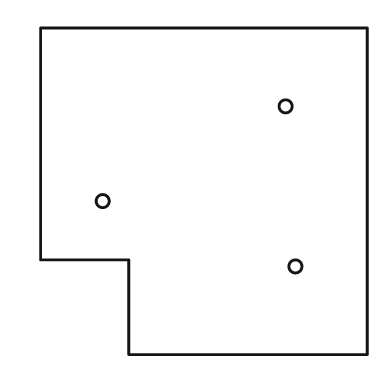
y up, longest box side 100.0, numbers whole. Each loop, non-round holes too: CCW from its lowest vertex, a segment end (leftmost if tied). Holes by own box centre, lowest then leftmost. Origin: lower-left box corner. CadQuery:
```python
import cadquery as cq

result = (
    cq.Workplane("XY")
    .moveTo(27.0, 0.0)
    .lineTo(100.0, 0.0)
    .lineTo(100.0, 100.0)
    .lineTo(0.0, 100.0)
    .lineTo(0.0, 29.0)
    .lineTo(27.0, 29.0)
    .close()
    .moveTo(78.0, 27.0)
    .circle(2.0)
    .moveTo(19.0, 47.0)
    .circle(2.0)
    .moveTo(75.0, 76.0)
    .circle(2.0)
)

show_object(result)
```